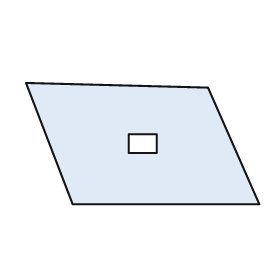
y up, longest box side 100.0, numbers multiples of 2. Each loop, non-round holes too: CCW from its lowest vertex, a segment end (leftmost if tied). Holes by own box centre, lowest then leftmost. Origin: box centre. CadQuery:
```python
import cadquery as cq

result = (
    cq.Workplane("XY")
    .moveTo(-30.0, -26.0)
    .lineTo(50.0, -26.0)
    .lineTo(28.0, 24.0)
    .lineTo(-50.0, 26.0)
    .close()
    .moveTo(-6.0, -4.0)
    .lineTo(6.0, -4.0)
    .lineTo(6.0, 4.0)
    .lineTo(-6.0, 4.0)
    .close()
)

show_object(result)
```